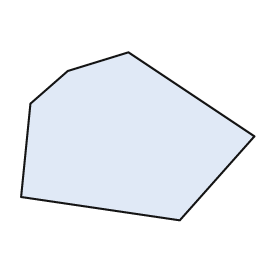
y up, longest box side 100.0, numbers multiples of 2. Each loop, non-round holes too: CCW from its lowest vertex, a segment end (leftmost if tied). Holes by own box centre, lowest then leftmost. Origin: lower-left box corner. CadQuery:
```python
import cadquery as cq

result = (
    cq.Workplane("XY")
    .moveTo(68.0, 0.0)
    .lineTo(100.0, 36.0)
    .lineTo(46.0, 72.0)
    .lineTo(20.0, 64.0)
    .lineTo(4.0, 50.0)
    .lineTo(0.0, 10.0)
    .close()
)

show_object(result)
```